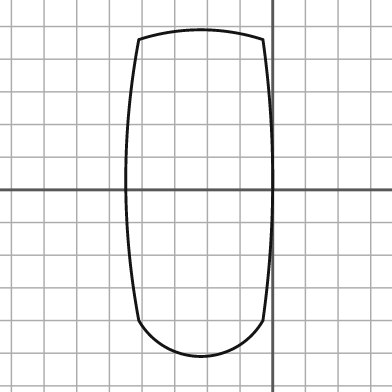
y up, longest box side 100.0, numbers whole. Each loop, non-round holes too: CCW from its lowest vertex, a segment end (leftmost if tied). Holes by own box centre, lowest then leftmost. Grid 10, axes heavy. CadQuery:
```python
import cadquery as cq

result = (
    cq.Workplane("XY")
    .moveTo(-41.0, -40.0)
    .threePointArc((-22.0, -51.0), (-3.0, -40.0))
    .threePointArc((0.0, 3.0), (-3.0, 46.0))
    .threePointArc((-22.0, 49.0), (-41.0, 46.0))
    .threePointArc((-45.0, 3.0), (-41.0, -40.0))
    .close()
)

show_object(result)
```